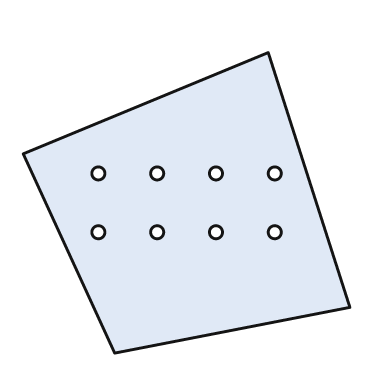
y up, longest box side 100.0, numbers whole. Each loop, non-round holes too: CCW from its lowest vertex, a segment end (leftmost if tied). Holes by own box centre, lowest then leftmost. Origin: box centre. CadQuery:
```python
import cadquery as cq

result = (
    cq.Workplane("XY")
    .moveTo(-22.0, -46.0)
    .lineTo(50.0, -32.0)
    .lineTo(25.0, 46.0)
    .lineTo(-50.0, 15.0)
    .close()
    .moveTo(-27.0, -9.0)
    .circle(2.0)
    .moveTo(-9.0, -9.0)
    .circle(2.0)
    .moveTo(9.0, -9.0)
    .circle(2.0)
    .moveTo(27.0, -9.0)
    .circle(2.0)
    .moveTo(-27.0, 9.0)
    .circle(2.0)
    .moveTo(-9.0, 9.0)
    .circle(2.0)
    .moveTo(9.0, 9.0)
    .circle(2.0)
    .moveTo(27.0, 9.0)
    .circle(2.0)
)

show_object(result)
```